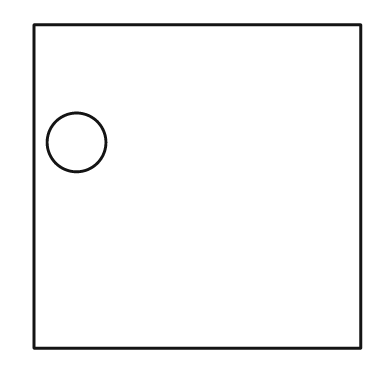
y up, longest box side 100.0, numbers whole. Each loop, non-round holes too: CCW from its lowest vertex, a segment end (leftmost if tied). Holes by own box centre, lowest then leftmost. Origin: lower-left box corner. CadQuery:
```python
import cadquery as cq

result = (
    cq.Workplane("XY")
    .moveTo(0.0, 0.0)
    .lineTo(100.0, 0.0)
    .lineTo(100.0, 99.0)
    .lineTo(0.0, 99.0)
    .close()
    .moveTo(13.0, 63.0)
    .circle(9.0)
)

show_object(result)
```